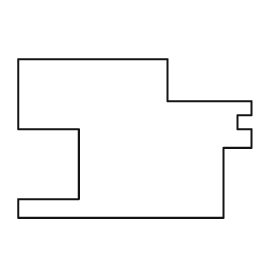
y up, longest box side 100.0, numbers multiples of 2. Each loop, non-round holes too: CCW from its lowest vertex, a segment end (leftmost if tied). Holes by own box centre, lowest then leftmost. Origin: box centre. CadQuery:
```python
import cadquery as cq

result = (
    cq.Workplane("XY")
    .moveTo(-50.0, -34.0)
    .lineTo(38.0, -34.0)
    .lineTo(38.0, -4.0)
    .lineTo(50.0, -4.0)
    .lineTo(50.0, 4.0)
    .lineTo(44.0, 4.0)
    .lineTo(44.0, 10.0)
    .lineTo(50.0, 10.0)
    .lineTo(50.0, 16.0)
    .lineTo(14.0, 16.0)
    .lineTo(14.0, 34.0)
    .lineTo(-50.0, 34.0)
    .lineTo(-50.0, 4.0)
    .lineTo(-24.0, 4.0)
    .lineTo(-24.0, -26.0)
    .lineTo(-50.0, -26.0)
    .close()
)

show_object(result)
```